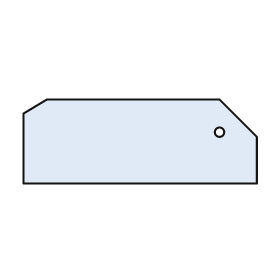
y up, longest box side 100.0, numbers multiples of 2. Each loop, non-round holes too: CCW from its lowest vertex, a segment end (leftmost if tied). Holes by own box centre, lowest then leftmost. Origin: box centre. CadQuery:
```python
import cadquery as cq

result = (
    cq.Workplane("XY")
    .moveTo(-50.0, -18.0)
    .lineTo(50.0, -18.0)
    .lineTo(50.0, 2.0)
    .lineTo(34.0, 18.0)
    .lineTo(-40.0, 18.0)
    .lineTo(-50.0, 12.0)
    .close()
    .moveTo(34.0, 4.0)
    .circle(2.0)
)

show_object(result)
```